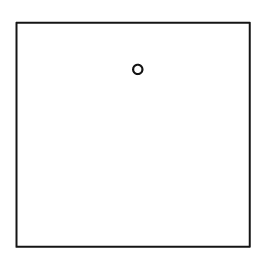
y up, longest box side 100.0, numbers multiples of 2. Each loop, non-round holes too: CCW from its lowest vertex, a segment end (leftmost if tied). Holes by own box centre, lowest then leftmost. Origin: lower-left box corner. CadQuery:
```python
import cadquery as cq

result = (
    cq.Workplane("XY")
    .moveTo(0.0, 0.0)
    .lineTo(100.0, 0.0)
    .lineTo(100.0, 96.0)
    .lineTo(0.0, 96.0)
    .close()
    .moveTo(52.0, 76.0)
    .circle(2.0)
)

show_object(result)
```